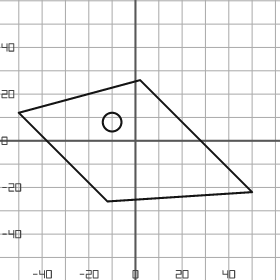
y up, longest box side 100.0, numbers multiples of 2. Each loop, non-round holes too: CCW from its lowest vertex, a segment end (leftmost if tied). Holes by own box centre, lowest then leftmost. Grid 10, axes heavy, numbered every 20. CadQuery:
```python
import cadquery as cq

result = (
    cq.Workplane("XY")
    .moveTo(-12.0, -26.0)
    .lineTo(50.0, -22.0)
    .lineTo(2.0, 26.0)
    .lineTo(-50.0, 12.0)
    .close()
    .moveTo(-10.0, 8.0)
    .circle(4.0)
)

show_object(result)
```